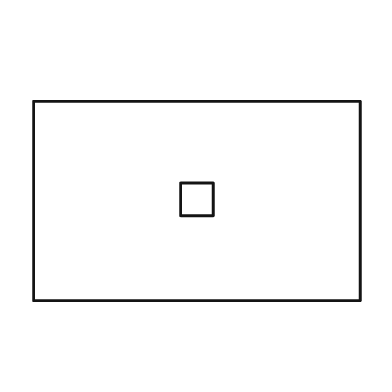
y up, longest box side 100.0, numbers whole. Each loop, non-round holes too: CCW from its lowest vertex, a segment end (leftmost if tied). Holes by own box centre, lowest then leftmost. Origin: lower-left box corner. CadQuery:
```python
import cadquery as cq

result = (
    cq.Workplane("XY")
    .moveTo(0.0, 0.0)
    .lineTo(100.0, 0.0)
    .lineTo(100.0, 61.0)
    .lineTo(0.0, 61.0)
    .close()
    .moveTo(45.0, 26.0)
    .lineTo(55.0, 26.0)
    .lineTo(55.0, 36.0)
    .lineTo(45.0, 36.0)
    .close()
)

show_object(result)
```